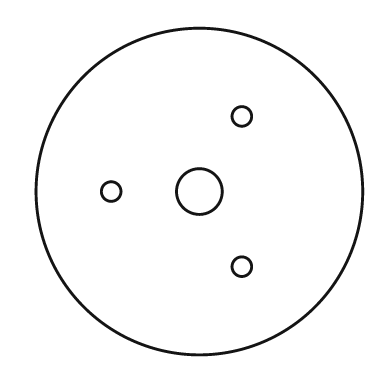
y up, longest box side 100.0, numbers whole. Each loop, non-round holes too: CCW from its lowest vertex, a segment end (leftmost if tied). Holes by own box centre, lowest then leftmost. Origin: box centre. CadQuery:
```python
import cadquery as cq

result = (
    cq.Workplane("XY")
    .moveTo(0.0, 0.0)
    .circle(50.0)
    .moveTo(13.0, -23.0)
    .circle(3.0)
    .moveTo(-27.0, 0.0)
    .circle(3.0)
    .moveTo(0.0, 0.0)
    .circle(7.0)
    .moveTo(13.0, 23.0)
    .circle(3.0)
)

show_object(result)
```